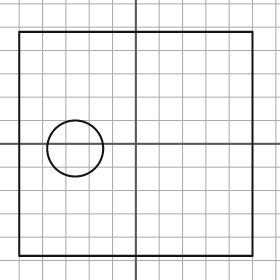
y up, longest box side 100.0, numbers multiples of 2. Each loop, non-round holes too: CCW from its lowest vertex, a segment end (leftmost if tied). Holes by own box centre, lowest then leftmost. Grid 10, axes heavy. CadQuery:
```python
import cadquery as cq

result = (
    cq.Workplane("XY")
    .moveTo(-50.0, -48.0)
    .lineTo(50.0, -48.0)
    .lineTo(50.0, 48.0)
    .lineTo(-50.0, 48.0)
    .close()
    .moveTo(-26.0, -2.0)
    .circle(12.0)
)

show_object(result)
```